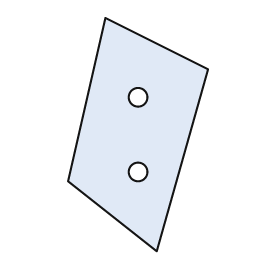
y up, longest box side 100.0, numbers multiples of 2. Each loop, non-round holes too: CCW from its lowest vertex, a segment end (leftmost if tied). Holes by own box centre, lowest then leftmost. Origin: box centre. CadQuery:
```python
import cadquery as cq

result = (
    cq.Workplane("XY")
    .moveTo(8.0, -50.0)
    .lineTo(30.0, 28.0)
    .lineTo(-14.0, 50.0)
    .lineTo(-30.0, -20.0)
    .close()
    .moveTo(0.0, -16.0)
    .circle(4.0)
    .moveTo(0.0, 16.0)
    .circle(4.0)
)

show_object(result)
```